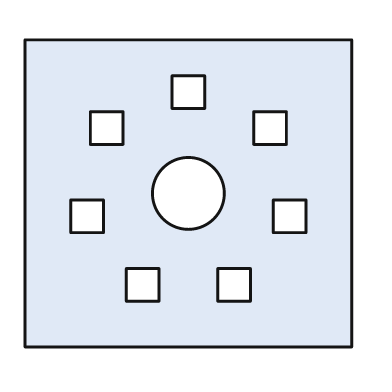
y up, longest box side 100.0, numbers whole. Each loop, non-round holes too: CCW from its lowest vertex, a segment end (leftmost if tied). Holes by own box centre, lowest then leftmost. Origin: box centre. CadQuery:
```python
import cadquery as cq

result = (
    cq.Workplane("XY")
    .moveTo(-50.0, -47.0)
    .lineTo(50.0, -47.0)
    .lineTo(50.0, 47.0)
    .lineTo(-50.0, 47.0)
    .close()
    .moveTo(-19.0, -33.0)
    .lineTo(-9.0, -33.0)
    .lineTo(-9.0, -23.0)
    .lineTo(-19.0, -23.0)
    .close()
    .moveTo(9.0, -33.0)
    .lineTo(19.0, -33.0)
    .lineTo(19.0, -23.0)
    .lineTo(9.0, -23.0)
    .close()
    .moveTo(-36.0, -12.0)
    .lineTo(-26.0, -12.0)
    .lineTo(-26.0, -2.0)
    .lineTo(-36.0, -2.0)
    .close()
    .moveTo(26.0, -12.0)
    .lineTo(36.0, -12.0)
    .lineTo(36.0, -2.0)
    .lineTo(26.0, -2.0)
    .close()
    .moveTo(0.0, 0.0)
    .circle(11.0)
    .moveTo(-30.0, 15.0)
    .lineTo(-20.0, 15.0)
    .lineTo(-20.0, 25.0)
    .lineTo(-30.0, 25.0)
    .close()
    .moveTo(20.0, 15.0)
    .lineTo(30.0, 15.0)
    .lineTo(30.0, 25.0)
    .lineTo(20.0, 25.0)
    .close()
    .moveTo(-5.0, 26.0)
    .lineTo(5.0, 26.0)
    .lineTo(5.0, 36.0)
    .lineTo(-5.0, 36.0)
    .close()
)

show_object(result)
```